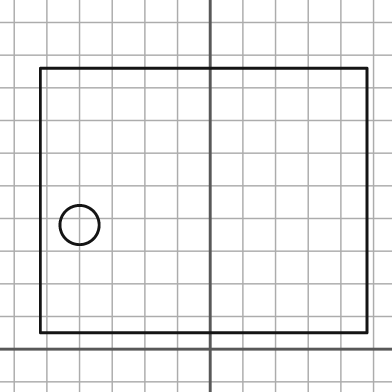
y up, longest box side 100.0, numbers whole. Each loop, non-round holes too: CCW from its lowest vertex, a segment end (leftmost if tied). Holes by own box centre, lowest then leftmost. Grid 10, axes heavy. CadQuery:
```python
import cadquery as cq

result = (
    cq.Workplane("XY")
    .moveTo(-52.0, 5.0)
    .lineTo(48.0, 5.0)
    .lineTo(48.0, 86.0)
    .lineTo(-52.0, 86.0)
    .close()
    .moveTo(-40.0, 38.0)
    .circle(6.0)
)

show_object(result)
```